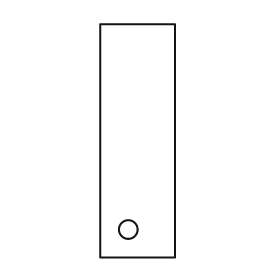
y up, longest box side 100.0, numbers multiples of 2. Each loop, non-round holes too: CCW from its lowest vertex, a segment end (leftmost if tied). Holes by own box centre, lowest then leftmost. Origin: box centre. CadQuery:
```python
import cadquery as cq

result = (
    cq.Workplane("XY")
    .moveTo(-16.0, -50.0)
    .lineTo(16.0, -50.0)
    .lineTo(16.0, 50.0)
    .lineTo(-16.0, 50.0)
    .close()
    .moveTo(-4.0, -38.0)
    .circle(4.0)
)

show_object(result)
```